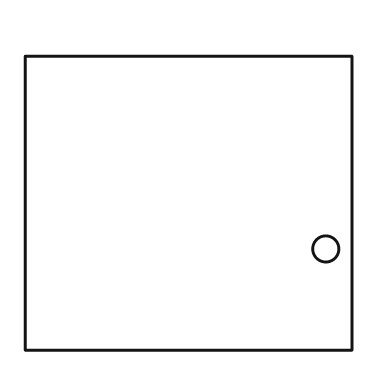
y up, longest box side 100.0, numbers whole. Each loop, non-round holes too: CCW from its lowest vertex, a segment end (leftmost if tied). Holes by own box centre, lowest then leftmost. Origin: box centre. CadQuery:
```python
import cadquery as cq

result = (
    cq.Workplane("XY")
    .moveTo(-50.0, -45.0)
    .lineTo(50.0, -45.0)
    .lineTo(50.0, 45.0)
    .lineTo(-50.0, 45.0)
    .close()
    .moveTo(42.0, -14.0)
    .circle(4.0)
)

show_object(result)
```